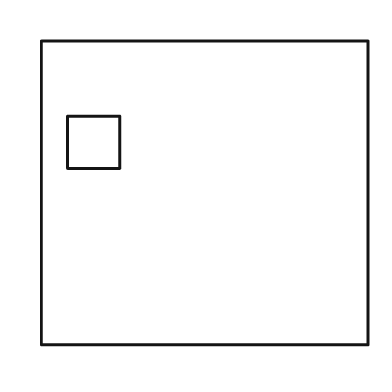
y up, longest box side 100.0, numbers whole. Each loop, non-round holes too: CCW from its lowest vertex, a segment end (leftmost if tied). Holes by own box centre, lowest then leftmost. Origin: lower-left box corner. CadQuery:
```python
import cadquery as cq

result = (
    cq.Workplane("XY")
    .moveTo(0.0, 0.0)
    .lineTo(100.0, 0.0)
    .lineTo(100.0, 93.0)
    .lineTo(0.0, 93.0)
    .close()
    .moveTo(8.0, 54.0)
    .lineTo(24.0, 54.0)
    .lineTo(24.0, 70.0)
    .lineTo(8.0, 70.0)
    .close()
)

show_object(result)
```